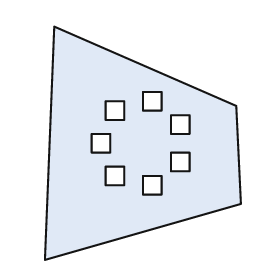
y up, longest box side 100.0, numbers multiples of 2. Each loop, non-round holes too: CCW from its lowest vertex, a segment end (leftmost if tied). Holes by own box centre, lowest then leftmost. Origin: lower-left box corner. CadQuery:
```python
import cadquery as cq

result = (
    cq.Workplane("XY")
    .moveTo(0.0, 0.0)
    .lineTo(84.0, 24.0)
    .lineTo(82.0, 66.0)
    .lineTo(4.0, 100.0)
    .close()
    .moveTo(42.0, 28.0)
    .lineTo(50.0, 28.0)
    .lineTo(50.0, 36.0)
    .lineTo(42.0, 36.0)
    .close()
    .moveTo(26.0, 32.0)
    .lineTo(34.0, 32.0)
    .lineTo(34.0, 40.0)
    .lineTo(26.0, 40.0)
    .close()
    .moveTo(54.0, 38.0)
    .lineTo(62.0, 38.0)
    .lineTo(62.0, 46.0)
    .lineTo(54.0, 46.0)
    .close()
    .moveTo(20.0, 46.0)
    .lineTo(28.0, 46.0)
    .lineTo(28.0, 54.0)
    .lineTo(20.0, 54.0)
    .close()
    .moveTo(54.0, 54.0)
    .lineTo(62.0, 54.0)
    .lineTo(62.0, 62.0)
    .lineTo(54.0, 62.0)
    .close()
    .moveTo(26.0, 60.0)
    .lineTo(34.0, 60.0)
    .lineTo(34.0, 68.0)
    .lineTo(26.0, 68.0)
    .close()
    .moveTo(42.0, 64.0)
    .lineTo(50.0, 64.0)
    .lineTo(50.0, 72.0)
    .lineTo(42.0, 72.0)
    .close()
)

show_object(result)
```